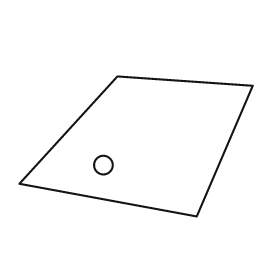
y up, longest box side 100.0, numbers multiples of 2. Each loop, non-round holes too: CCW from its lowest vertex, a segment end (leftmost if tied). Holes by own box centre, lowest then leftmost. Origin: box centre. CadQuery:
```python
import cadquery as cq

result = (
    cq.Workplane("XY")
    .moveTo(26.0, -30.0)
    .lineTo(50.0, 26.0)
    .lineTo(-8.0, 30.0)
    .lineTo(-50.0, -16.0)
    .close()
    .moveTo(-14.0, -8.0)
    .circle(4.0)
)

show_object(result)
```